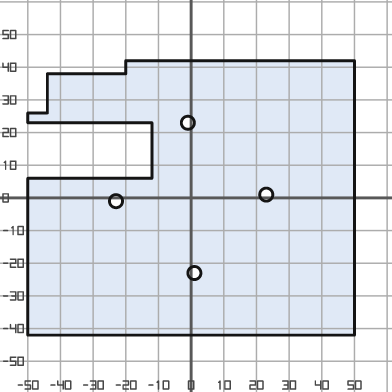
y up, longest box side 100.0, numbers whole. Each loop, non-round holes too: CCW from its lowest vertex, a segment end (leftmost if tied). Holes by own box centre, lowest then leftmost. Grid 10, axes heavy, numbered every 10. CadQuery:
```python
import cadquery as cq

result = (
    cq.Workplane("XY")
    .moveTo(-50.0, -42.0)
    .lineTo(50.0, -42.0)
    .lineTo(50.0, 42.0)
    .lineTo(-20.0, 42.0)
    .lineTo(-20.0, 38.0)
    .lineTo(-44.0, 38.0)
    .lineTo(-44.0, 26.0)
    .lineTo(-50.0, 26.0)
    .lineTo(-50.0, 23.0)
    .lineTo(-12.0, 23.0)
    .lineTo(-12.0, 6.0)
    .lineTo(-50.0, 6.0)
    .close()
    .moveTo(1.0, -23.0)
    .circle(2.0)
    .moveTo(-23.0, -1.0)
    .circle(2.0)
    .moveTo(23.0, 1.0)
    .circle(2.0)
    .moveTo(-1.0, 23.0)
    .circle(2.0)
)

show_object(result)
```